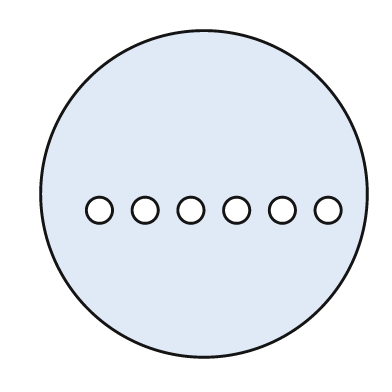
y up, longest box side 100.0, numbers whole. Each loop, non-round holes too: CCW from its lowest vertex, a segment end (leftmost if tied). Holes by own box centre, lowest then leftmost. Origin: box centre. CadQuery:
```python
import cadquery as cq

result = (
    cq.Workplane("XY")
    .moveTo(0.0, 0.0)
    .circle(50.0)
    .moveTo(-32.0, -5.0)
    .circle(4.0)
    .moveTo(-18.0, -5.0)
    .circle(4.0)
    .moveTo(-4.0, -5.0)
    .circle(4.0)
    .moveTo(10.0, -5.0)
    .circle(4.0)
    .moveTo(24.0, -5.0)
    .circle(4.0)
    .moveTo(38.0, -5.0)
    .circle(4.0)
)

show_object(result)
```